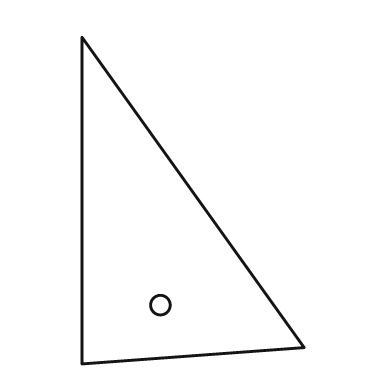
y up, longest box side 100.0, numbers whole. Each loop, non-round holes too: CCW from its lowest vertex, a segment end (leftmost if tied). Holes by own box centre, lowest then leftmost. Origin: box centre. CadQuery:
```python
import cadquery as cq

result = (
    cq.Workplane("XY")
    .moveTo(-34.0, -50.0)
    .lineTo(34.0, -45.0)
    .lineTo(-34.0, 50.0)
    .close()
    .moveTo(-10.0, -32.0)
    .circle(3.0)
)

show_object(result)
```